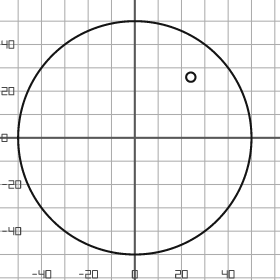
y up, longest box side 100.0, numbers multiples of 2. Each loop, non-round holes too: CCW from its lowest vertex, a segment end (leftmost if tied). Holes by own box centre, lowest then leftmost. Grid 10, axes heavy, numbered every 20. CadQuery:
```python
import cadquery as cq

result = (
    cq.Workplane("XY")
    .moveTo(0.0, 0.0)
    .circle(50.0)
    .moveTo(24.0, 26.0)
    .circle(2.0)
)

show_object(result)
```